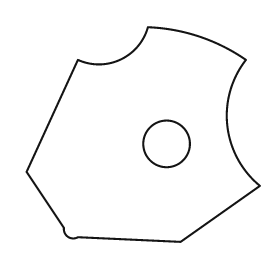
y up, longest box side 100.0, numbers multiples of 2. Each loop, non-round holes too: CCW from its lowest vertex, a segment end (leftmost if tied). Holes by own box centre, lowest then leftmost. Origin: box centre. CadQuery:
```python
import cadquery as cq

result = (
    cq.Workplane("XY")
    .moveTo(16.0, -46.0)
    .lineTo(50.0, -22.0)
    .threePointArc((36.0, 4.0), (44.0, 32.0))
    .threePointArc((24.0, 42.0), (2.0, 46.0))
    .threePointArc((-10.0, 32.0), (-28.0, 32.0))
    .lineTo(-50.0, -16.0)
    .lineTo(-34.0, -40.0)
    .threePointArc((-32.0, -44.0), (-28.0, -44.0))
    .close()
    .moveTo(10.0, -4.0)
    .circle(10.0)
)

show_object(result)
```